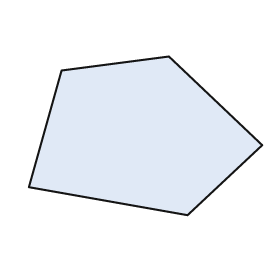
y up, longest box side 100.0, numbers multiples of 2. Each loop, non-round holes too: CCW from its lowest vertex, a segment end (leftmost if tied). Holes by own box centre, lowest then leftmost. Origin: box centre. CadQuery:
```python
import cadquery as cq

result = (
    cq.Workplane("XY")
    .moveTo(18.0, -34.0)
    .lineTo(50.0, -4.0)
    .lineTo(10.0, 34.0)
    .lineTo(-36.0, 28.0)
    .lineTo(-50.0, -22.0)
    .close()
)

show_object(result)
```